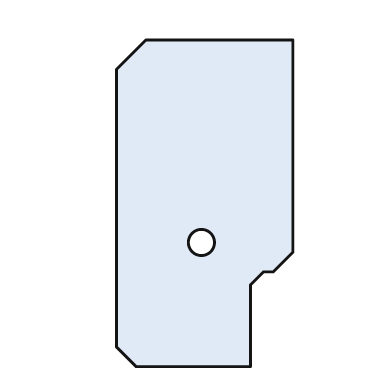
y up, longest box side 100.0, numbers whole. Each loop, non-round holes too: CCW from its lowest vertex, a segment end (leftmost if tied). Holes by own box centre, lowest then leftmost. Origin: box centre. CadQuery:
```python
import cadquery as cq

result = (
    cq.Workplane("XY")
    .moveTo(-21.0, -50.0)
    .lineTo(14.0, -50.0)
    .lineTo(14.0, -25.0)
    .lineTo(18.0, -21.0)
    .lineTo(21.0, -21.0)
    .lineTo(27.0, -15.0)
    .lineTo(27.0, 50.0)
    .lineTo(-18.0, 50.0)
    .lineTo(-27.0, 41.0)
    .lineTo(-27.0, -44.0)
    .close()
    .moveTo(-1.0, -12.0)
    .circle(4.0)
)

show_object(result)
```